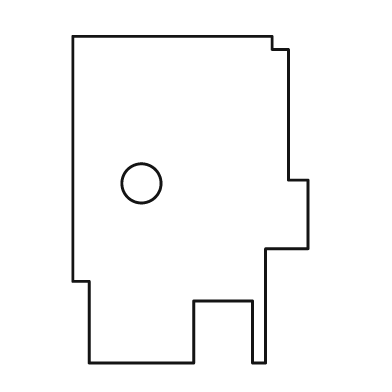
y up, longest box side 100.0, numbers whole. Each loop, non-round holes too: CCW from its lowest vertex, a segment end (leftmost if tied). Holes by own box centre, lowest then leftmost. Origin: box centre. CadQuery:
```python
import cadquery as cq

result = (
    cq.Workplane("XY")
    .moveTo(-31.0, -50.0)
    .lineTo(1.0, -50.0)
    .lineTo(1.0, -31.0)
    .lineTo(19.0, -31.0)
    .lineTo(19.0, -50.0)
    .lineTo(23.0, -50.0)
    .lineTo(23.0, -15.0)
    .lineTo(36.0, -15.0)
    .lineTo(36.0, 6.0)
    .lineTo(30.0, 6.0)
    .lineTo(30.0, 46.0)
    .lineTo(25.0, 46.0)
    .lineTo(25.0, 50.0)
    .lineTo(-36.0, 50.0)
    .lineTo(-36.0, -25.0)
    .lineTo(-31.0, -25.0)
    .close()
    .moveTo(-15.0, 5.0)
    .circle(6.0)
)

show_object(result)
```